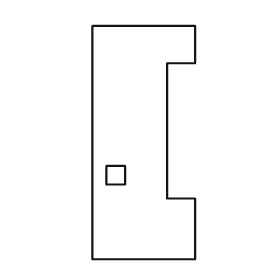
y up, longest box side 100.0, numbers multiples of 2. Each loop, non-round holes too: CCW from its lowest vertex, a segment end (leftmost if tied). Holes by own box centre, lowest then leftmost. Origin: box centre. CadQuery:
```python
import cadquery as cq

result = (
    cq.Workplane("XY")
    .moveTo(-22.0, -50.0)
    .lineTo(22.0, -50.0)
    .lineTo(22.0, -24.0)
    .lineTo(10.0, -24.0)
    .lineTo(10.0, 34.0)
    .lineTo(22.0, 34.0)
    .lineTo(22.0, 50.0)
    .lineTo(-22.0, 50.0)
    .close()
    .moveTo(-16.0, -18.0)
    .lineTo(-8.0, -18.0)
    .lineTo(-8.0, -10.0)
    .lineTo(-16.0, -10.0)
    .close()
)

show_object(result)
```